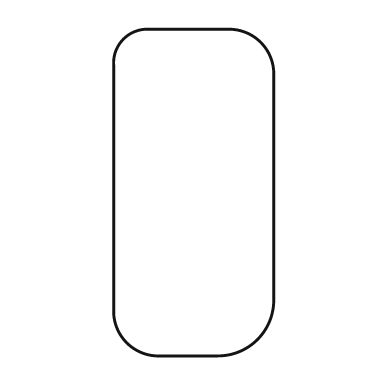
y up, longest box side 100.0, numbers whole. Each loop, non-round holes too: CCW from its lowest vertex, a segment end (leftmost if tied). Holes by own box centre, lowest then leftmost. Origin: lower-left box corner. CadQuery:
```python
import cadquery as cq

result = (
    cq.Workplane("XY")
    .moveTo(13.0, 0.0)
    .lineTo(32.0, 0.0)
    .threePointArc((44.0, 5.0), (49.0, 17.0))
    .lineTo(49.0, 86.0)
    .threePointArc((45.0, 96.0), (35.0, 100.0))
    .lineTo(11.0, 100.0)
    .threePointArc((3.0, 97.0), (0.0, 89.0))
    .lineTo(0.0, 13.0)
    .threePointArc((4.0, 4.0), (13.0, 0.0))
    .close()
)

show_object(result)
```